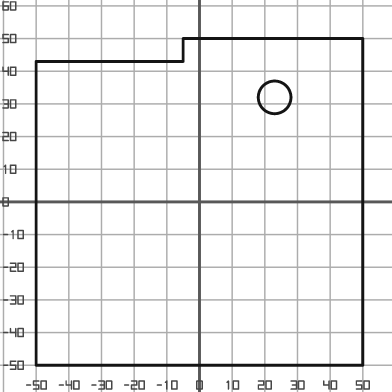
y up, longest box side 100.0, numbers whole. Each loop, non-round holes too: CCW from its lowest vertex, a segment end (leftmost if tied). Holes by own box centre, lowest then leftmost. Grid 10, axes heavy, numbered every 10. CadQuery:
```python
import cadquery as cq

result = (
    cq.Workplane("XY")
    .moveTo(-50.0, -50.0)
    .lineTo(50.0, -50.0)
    .lineTo(50.0, 50.0)
    .lineTo(-5.0, 50.0)
    .lineTo(-5.0, 43.0)
    .lineTo(-50.0, 43.0)
    .close()
    .moveTo(23.0, 32.0)
    .circle(5.0)
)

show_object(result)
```